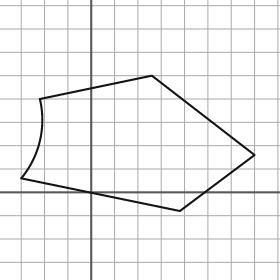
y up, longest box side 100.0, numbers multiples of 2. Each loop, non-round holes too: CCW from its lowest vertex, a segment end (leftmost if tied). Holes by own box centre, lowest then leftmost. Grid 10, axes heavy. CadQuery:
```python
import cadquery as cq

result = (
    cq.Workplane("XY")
    .moveTo(38.0, -8.0)
    .lineTo(70.0, 16.0)
    .lineTo(26.0, 50.0)
    .lineTo(-22.0, 40.0)
    .threePointArc((-22.0, 22.0), (-30.0, 6.0))
    .close()
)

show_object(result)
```